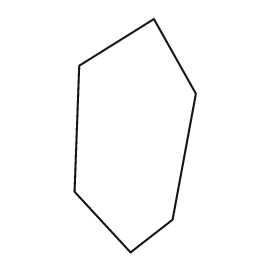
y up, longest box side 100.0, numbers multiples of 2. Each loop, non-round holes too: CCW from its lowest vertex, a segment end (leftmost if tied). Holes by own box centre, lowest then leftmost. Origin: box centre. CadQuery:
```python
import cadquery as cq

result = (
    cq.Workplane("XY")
    .moveTo(-2.0, -50.0)
    .lineTo(16.0, -36.0)
    .lineTo(26.0, 18.0)
    .lineTo(8.0, 50.0)
    .lineTo(-24.0, 30.0)
    .lineTo(-26.0, -24.0)
    .close()
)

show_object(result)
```